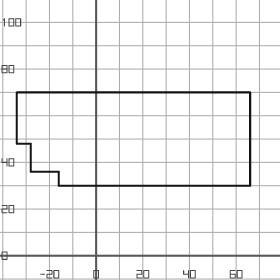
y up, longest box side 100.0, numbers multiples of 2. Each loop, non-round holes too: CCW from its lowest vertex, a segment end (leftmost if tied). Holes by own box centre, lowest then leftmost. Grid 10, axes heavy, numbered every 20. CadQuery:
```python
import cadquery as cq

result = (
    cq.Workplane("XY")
    .moveTo(-16.0, 30.0)
    .lineTo(66.0, 30.0)
    .lineTo(66.0, 70.0)
    .lineTo(-34.0, 70.0)
    .lineTo(-34.0, 48.0)
    .lineTo(-28.0, 48.0)
    .lineTo(-28.0, 36.0)
    .lineTo(-16.0, 36.0)
    .close()
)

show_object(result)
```